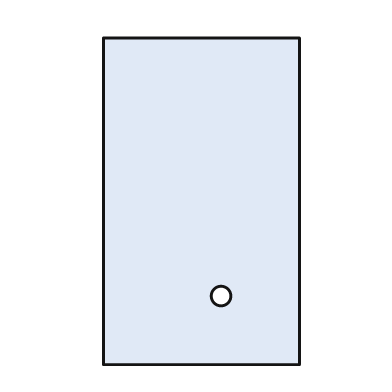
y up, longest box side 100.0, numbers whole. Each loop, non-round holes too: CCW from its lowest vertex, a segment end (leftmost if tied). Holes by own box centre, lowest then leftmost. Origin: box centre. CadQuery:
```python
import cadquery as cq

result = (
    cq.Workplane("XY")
    .moveTo(-30.0, -50.0)
    .lineTo(30.0, -50.0)
    .lineTo(30.0, 50.0)
    .lineTo(-30.0, 50.0)
    .close()
    .moveTo(6.0, -29.0)
    .circle(3.0)
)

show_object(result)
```